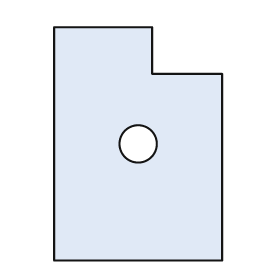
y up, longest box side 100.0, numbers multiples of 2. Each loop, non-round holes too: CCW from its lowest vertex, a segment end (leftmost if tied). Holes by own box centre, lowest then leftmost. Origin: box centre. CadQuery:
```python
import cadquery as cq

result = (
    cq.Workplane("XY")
    .moveTo(-36.0, -50.0)
    .lineTo(36.0, -50.0)
    .lineTo(36.0, 30.0)
    .lineTo(6.0, 30.0)
    .lineTo(6.0, 50.0)
    .lineTo(-36.0, 50.0)
    .close()
    .moveTo(0.0, 0.0)
    .circle(8.0)
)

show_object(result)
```